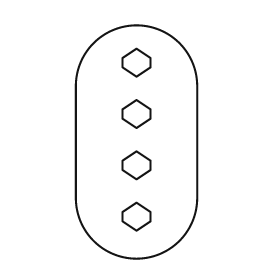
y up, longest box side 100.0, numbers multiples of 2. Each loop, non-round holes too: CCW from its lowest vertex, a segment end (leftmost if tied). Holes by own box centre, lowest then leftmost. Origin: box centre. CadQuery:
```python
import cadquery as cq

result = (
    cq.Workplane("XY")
    .moveTo(-26.0, -24.0)
    .threePointArc((0.0, -50.0), (26.0, -24.0))
    .lineTo(26.0, 24.0)
    .threePointArc((0.0, 50.0), (-26.0, 24.0))
    .close()
    .moveTo(0.0, -38.0)
    .lineTo(6.0, -34.0)
    .lineTo(6.0, -30.0)
    .lineTo(0.0, -26.0)
    .lineTo(-6.0, -30.0)
    .lineTo(-6.0, -34.0)
    .close()
    .moveTo(0.0, -16.0)
    .lineTo(6.0, -12.0)
    .lineTo(6.0, -8.0)
    .lineTo(0.0, -4.0)
    .lineTo(-6.0, -8.0)
    .lineTo(-6.0, -12.0)
    .close()
    .moveTo(0.0, 6.0)
    .lineTo(6.0, 10.0)
    .lineTo(6.0, 14.0)
    .lineTo(0.0, 18.0)
    .lineTo(-6.0, 14.0)
    .lineTo(-6.0, 10.0)
    .close()
    .moveTo(0.0, 28.0)
    .lineTo(6.0, 32.0)
    .lineTo(6.0, 36.0)
    .lineTo(0.0, 40.0)
    .lineTo(-6.0, 36.0)
    .lineTo(-6.0, 32.0)
    .close()
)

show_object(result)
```